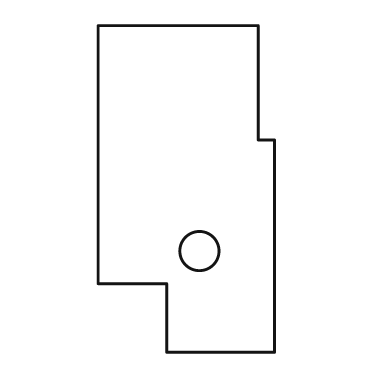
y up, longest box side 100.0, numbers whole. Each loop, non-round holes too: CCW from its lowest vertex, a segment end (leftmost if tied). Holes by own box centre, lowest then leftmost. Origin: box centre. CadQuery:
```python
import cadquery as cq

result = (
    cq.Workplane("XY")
    .moveTo(-6.0, -50.0)
    .lineTo(27.0, -50.0)
    .lineTo(27.0, 15.0)
    .lineTo(22.0, 15.0)
    .lineTo(22.0, 50.0)
    .lineTo(-27.0, 50.0)
    .lineTo(-27.0, -29.0)
    .lineTo(-6.0, -29.0)
    .close()
    .moveTo(4.0, -19.0)
    .circle(6.0)
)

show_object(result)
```